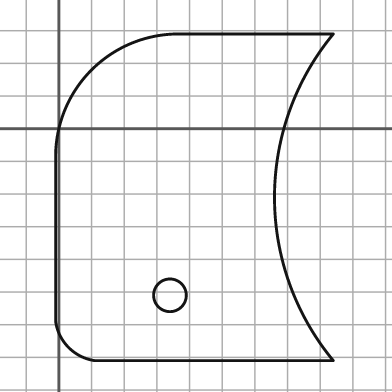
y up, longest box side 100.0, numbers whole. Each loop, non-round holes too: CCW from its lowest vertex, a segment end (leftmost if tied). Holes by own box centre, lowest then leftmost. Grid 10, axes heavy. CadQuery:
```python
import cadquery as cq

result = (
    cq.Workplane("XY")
    .moveTo(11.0, -71.0)
    .lineTo(84.0, -71.0)
    .threePointArc((66.0, -21.0), (84.0, 29.0))
    .lineTo(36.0, 29.0)
    .threePointArc((10.0, 18.0), (-1.0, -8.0))
    .lineTo(-1.0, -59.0)
    .threePointArc((3.0, -67.0), (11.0, -71.0))
    .close()
    .moveTo(34.0, -51.0)
    .circle(5.0)
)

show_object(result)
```